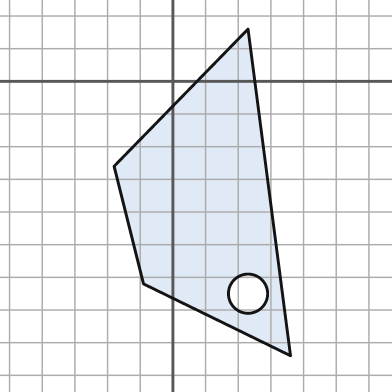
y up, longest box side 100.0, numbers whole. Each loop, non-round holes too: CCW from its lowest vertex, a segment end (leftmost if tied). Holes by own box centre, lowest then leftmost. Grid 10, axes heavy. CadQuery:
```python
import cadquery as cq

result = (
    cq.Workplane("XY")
    .moveTo(36.0, -84.0)
    .lineTo(23.0, 16.0)
    .lineTo(-18.0, -26.0)
    .lineTo(-9.0, -62.0)
    .close()
    .moveTo(23.0, -65.0)
    .circle(6.0)
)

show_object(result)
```